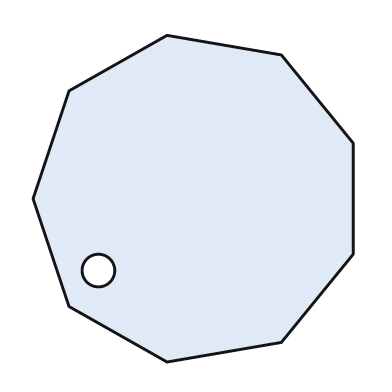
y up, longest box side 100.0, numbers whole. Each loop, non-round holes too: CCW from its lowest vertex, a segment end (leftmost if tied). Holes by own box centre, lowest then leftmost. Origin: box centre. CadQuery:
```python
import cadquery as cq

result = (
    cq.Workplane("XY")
    .moveTo(-8.0, -50.0)
    .lineTo(27.0, -44.0)
    .lineTo(49.0, -17.0)
    .lineTo(49.0, 17.0)
    .lineTo(27.0, 44.0)
    .lineTo(-8.0, 50.0)
    .lineTo(-38.0, 33.0)
    .lineTo(-49.0, 0.0)
    .lineTo(-38.0, -33.0)
    .close()
    .moveTo(-29.0, -22.0)
    .circle(5.0)
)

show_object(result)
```